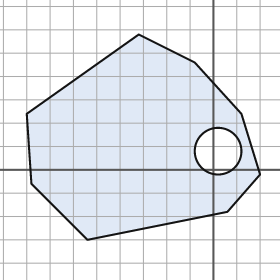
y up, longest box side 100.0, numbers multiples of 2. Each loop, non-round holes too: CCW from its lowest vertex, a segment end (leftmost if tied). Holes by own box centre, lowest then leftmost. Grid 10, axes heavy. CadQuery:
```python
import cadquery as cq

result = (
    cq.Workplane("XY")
    .moveTo(-54.0, -30.0)
    .lineTo(6.0, -18.0)
    .lineTo(20.0, -2.0)
    .lineTo(12.0, 24.0)
    .lineTo(-8.0, 46.0)
    .lineTo(-32.0, 58.0)
    .lineTo(-80.0, 24.0)
    .lineTo(-78.0, -6.0)
    .close()
    .moveTo(2.0, 8.0)
    .circle(10.0)
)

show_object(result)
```